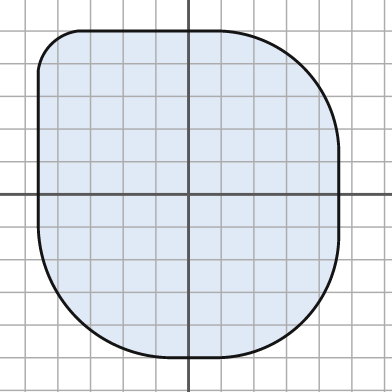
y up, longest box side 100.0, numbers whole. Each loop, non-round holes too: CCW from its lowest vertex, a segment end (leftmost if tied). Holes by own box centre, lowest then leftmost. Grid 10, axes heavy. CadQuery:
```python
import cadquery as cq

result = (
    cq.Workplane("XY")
    .moveTo(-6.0, -50.0)
    .lineTo(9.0, -50.0)
    .threePointArc((35.0, -39.0), (46.0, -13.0))
    .lineTo(46.0, 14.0)
    .threePointArc((35.0, 39.0), (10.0, 50.0))
    .lineTo(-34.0, 50.0)
    .threePointArc((-42.0, 46.0), (-46.0, 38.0))
    .lineTo(-46.0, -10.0)
    .threePointArc((-34.0, -38.0), (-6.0, -50.0))
    .close()
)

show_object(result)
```